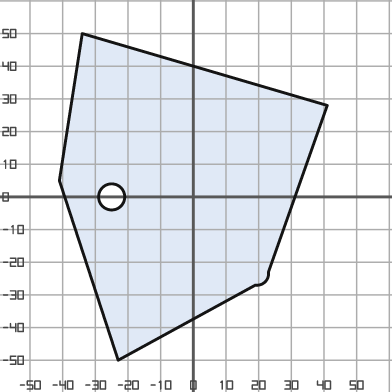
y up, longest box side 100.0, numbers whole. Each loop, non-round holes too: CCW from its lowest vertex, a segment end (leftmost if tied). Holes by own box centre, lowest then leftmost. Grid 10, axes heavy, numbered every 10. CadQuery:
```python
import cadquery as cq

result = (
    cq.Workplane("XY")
    .moveTo(-23.0, -50.0)
    .lineTo(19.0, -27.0)
    .threePointArc((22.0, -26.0), (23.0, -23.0))
    .lineTo(41.0, 28.0)
    .lineTo(-34.0, 50.0)
    .lineTo(-41.0, 5.0)
    .close()
    .moveTo(-25.0, 0.0)
    .circle(4.0)
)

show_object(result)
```